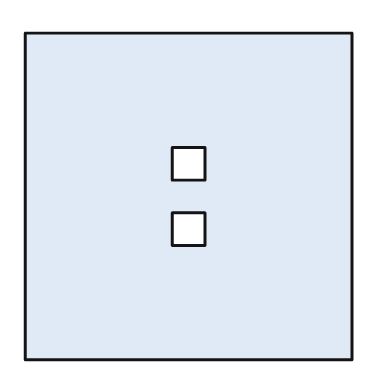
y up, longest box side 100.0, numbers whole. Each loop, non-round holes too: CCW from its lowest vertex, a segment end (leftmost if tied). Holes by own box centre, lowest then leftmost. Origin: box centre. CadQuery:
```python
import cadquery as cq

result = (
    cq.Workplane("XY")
    .moveTo(-50.0, -50.0)
    .lineTo(50.0, -50.0)
    .lineTo(50.0, 50.0)
    .lineTo(-50.0, 50.0)
    .close()
    .moveTo(-5.0, -15.0)
    .lineTo(5.0, -15.0)
    .lineTo(5.0, -5.0)
    .lineTo(-5.0, -5.0)
    .close()
    .moveTo(-5.0, 5.0)
    .lineTo(5.0, 5.0)
    .lineTo(5.0, 15.0)
    .lineTo(-5.0, 15.0)
    .close()
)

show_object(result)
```